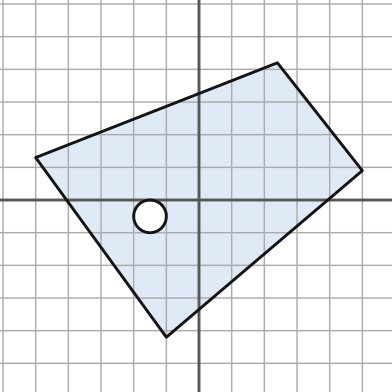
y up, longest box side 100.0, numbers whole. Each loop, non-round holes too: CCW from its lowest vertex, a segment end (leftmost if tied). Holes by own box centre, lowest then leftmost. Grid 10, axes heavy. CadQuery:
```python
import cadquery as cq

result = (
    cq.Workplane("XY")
    .moveTo(-10.0, -42.0)
    .lineTo(50.0, 9.0)
    .lineTo(24.0, 42.0)
    .lineTo(-50.0, 13.0)
    .close()
    .moveTo(-15.0, -5.0)
    .circle(5.0)
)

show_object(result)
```